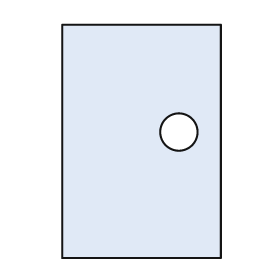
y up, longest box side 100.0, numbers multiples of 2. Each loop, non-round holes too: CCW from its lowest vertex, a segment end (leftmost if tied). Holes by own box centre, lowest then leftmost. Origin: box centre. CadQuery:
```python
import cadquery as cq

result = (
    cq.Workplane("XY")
    .moveTo(-34.0, -50.0)
    .lineTo(34.0, -50.0)
    .lineTo(34.0, 50.0)
    .lineTo(-34.0, 50.0)
    .close()
    .moveTo(16.0, 4.0)
    .circle(8.0)
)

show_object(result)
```